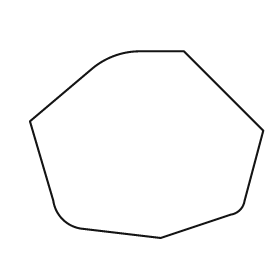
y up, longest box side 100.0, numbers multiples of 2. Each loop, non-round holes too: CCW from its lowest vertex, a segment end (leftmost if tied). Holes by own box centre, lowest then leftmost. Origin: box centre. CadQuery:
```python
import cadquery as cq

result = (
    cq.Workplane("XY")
    .moveTo(6.0, -40.0)
    .lineTo(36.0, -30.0)
    .threePointArc((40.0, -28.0), (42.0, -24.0))
    .lineTo(50.0, 6.0)
    .lineTo(16.0, 40.0)
    .lineTo(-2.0, 40.0)
    .threePointArc((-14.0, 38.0), (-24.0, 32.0))
    .lineTo(-50.0, 10.0)
    .lineTo(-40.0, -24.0)
    .threePointArc((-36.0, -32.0), (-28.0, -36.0))
    .close()
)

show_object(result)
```